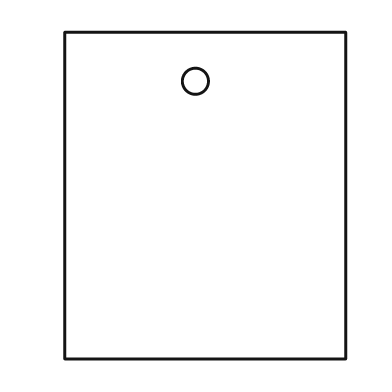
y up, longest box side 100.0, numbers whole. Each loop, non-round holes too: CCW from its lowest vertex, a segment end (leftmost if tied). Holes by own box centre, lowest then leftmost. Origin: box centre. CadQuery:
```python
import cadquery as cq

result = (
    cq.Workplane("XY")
    .moveTo(-43.0, -50.0)
    .lineTo(43.0, -50.0)
    .lineTo(43.0, 50.0)
    .lineTo(-43.0, 50.0)
    .close()
    .moveTo(-3.0, 35.0)
    .circle(4.0)
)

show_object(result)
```